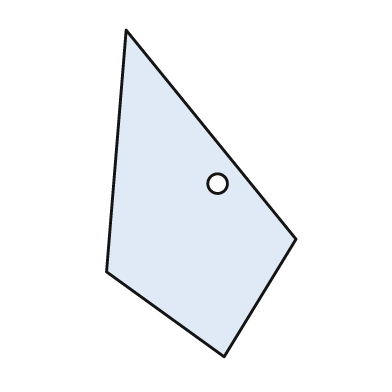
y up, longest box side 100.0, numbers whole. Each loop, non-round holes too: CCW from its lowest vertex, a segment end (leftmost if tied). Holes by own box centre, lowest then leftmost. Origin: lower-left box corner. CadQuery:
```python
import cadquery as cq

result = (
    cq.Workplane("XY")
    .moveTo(36.0, 0.0)
    .lineTo(58.0, 36.0)
    .lineTo(6.0, 100.0)
    .lineTo(0.0, 26.0)
    .close()
    .moveTo(34.0, 53.0)
    .circle(3.0)
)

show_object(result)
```